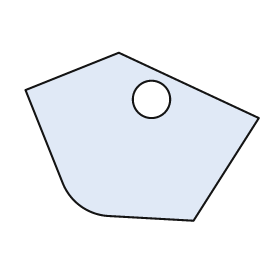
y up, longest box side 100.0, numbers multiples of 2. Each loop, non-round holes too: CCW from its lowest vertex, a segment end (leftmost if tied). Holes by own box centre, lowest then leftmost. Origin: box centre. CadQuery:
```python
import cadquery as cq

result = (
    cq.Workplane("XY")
    .moveTo(22.0, -36.0)
    .lineTo(50.0, 8.0)
    .lineTo(-10.0, 36.0)
    .lineTo(-50.0, 20.0)
    .lineTo(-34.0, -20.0)
    .threePointArc((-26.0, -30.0), (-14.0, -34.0))
    .close()
    .moveTo(4.0, 16.0)
    .circle(8.0)
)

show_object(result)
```